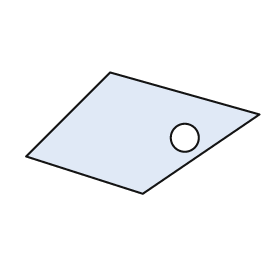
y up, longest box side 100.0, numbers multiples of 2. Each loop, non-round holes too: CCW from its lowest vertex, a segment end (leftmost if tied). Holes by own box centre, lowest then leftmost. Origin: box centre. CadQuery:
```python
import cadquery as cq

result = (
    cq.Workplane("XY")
    .moveTo(0.0, -26.0)
    .lineTo(50.0, 8.0)
    .lineTo(-14.0, 26.0)
    .lineTo(-50.0, -10.0)
    .close()
    .moveTo(18.0, -2.0)
    .circle(6.0)
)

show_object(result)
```